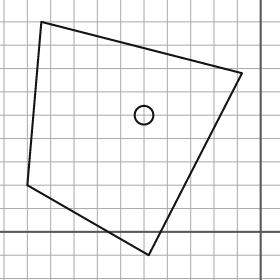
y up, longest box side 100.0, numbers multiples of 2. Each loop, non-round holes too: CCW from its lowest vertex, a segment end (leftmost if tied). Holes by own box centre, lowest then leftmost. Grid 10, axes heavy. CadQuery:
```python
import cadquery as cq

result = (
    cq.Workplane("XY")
    .moveTo(-48.0, -10.0)
    .lineTo(-8.0, 68.0)
    .lineTo(-94.0, 90.0)
    .lineTo(-100.0, 20.0)
    .close()
    .moveTo(-50.0, 50.0)
    .circle(4.0)
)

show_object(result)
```